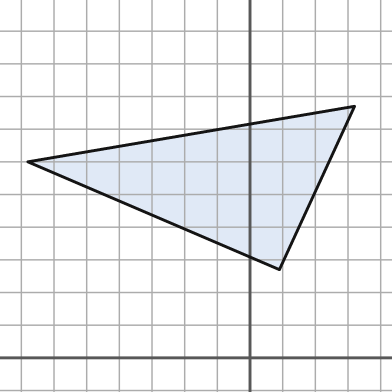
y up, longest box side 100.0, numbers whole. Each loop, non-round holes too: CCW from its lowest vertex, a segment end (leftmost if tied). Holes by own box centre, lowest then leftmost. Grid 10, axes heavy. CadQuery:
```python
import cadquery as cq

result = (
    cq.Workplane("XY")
    .moveTo(9.0, 27.0)
    .lineTo(32.0, 77.0)
    .lineTo(-68.0, 60.0)
    .close()
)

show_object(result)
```